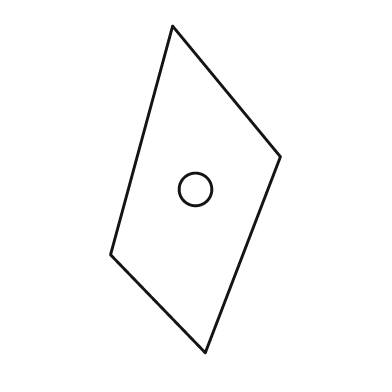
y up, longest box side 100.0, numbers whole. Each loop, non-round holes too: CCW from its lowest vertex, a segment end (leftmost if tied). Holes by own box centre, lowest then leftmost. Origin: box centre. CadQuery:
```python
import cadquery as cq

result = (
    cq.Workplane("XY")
    .moveTo(3.0, -50.0)
    .lineTo(26.0, 10.0)
    .lineTo(-7.0, 50.0)
    .lineTo(-26.0, -20.0)
    .close()
    .moveTo(0.0, 0.0)
    .circle(5.0)
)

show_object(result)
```